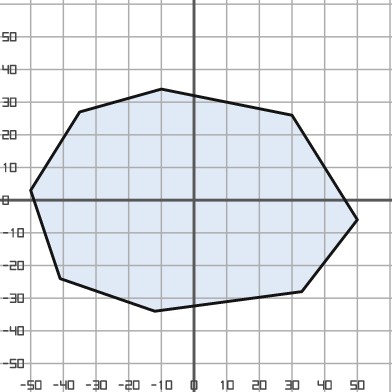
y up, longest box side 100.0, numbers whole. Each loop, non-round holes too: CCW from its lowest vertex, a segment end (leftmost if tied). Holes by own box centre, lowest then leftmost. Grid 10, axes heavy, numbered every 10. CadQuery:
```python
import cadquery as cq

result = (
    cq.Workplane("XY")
    .moveTo(-12.0, -34.0)
    .lineTo(33.0, -28.0)
    .lineTo(50.0, -6.0)
    .lineTo(30.0, 26.0)
    .lineTo(-10.0, 34.0)
    .lineTo(-35.0, 27.0)
    .lineTo(-50.0, 3.0)
    .lineTo(-41.0, -24.0)
    .close()
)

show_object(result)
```